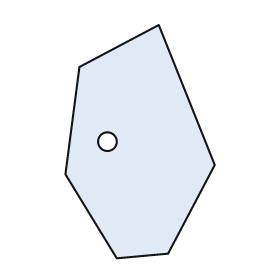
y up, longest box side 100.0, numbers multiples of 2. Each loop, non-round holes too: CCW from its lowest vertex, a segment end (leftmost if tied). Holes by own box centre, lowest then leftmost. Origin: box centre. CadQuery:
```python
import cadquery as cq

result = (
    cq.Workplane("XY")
    .moveTo(-10.0, -50.0)
    .lineTo(12.0, -48.0)
    .lineTo(32.0, -10.0)
    .lineTo(8.0, 50.0)
    .lineTo(-26.0, 32.0)
    .lineTo(-32.0, -14.0)
    .close()
    .moveTo(-14.0, 0.0)
    .circle(4.0)
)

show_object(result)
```